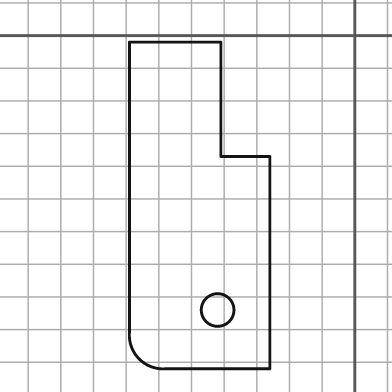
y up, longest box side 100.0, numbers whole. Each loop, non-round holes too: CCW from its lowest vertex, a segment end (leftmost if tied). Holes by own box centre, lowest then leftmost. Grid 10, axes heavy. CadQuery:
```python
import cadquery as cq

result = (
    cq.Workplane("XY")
    .moveTo(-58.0, -102.0)
    .lineTo(-26.0, -102.0)
    .lineTo(-26.0, -37.0)
    .lineTo(-41.0, -37.0)
    .lineTo(-41.0, -2.0)
    .lineTo(-69.0, -2.0)
    .lineTo(-69.0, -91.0)
    .threePointArc((-66.0, -99.0), (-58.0, -102.0))
    .close()
    .moveTo(-42.0, -84.0)
    .circle(5.0)
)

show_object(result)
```